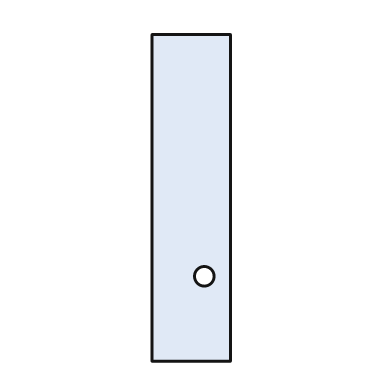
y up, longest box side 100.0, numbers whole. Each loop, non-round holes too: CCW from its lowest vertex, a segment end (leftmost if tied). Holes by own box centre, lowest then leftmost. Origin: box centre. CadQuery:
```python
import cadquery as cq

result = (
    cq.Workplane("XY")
    .moveTo(-12.0, -50.0)
    .lineTo(12.0, -50.0)
    .lineTo(12.0, 50.0)
    .lineTo(-12.0, 50.0)
    .close()
    .moveTo(4.0, -24.0)
    .circle(3.0)
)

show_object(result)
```